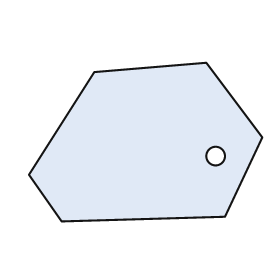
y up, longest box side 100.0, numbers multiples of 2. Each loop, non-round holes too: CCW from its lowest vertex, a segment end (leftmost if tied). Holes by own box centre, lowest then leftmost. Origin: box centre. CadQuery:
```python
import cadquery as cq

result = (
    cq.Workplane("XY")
    .moveTo(-36.0, -34.0)
    .lineTo(34.0, -32.0)
    .lineTo(50.0, 2.0)
    .lineTo(26.0, 34.0)
    .lineTo(-22.0, 30.0)
    .lineTo(-50.0, -14.0)
    .close()
    .moveTo(30.0, -6.0)
    .circle(4.0)
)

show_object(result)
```